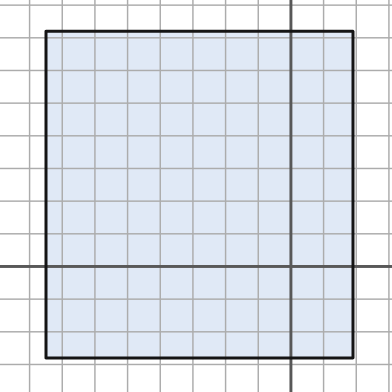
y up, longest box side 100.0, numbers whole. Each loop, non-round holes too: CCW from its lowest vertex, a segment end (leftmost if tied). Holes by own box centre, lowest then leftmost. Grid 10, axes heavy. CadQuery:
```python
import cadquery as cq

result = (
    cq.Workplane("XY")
    .moveTo(-75.0, -28.0)
    .lineTo(19.0, -28.0)
    .lineTo(19.0, 72.0)
    .lineTo(-75.0, 72.0)
    .close()
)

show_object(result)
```